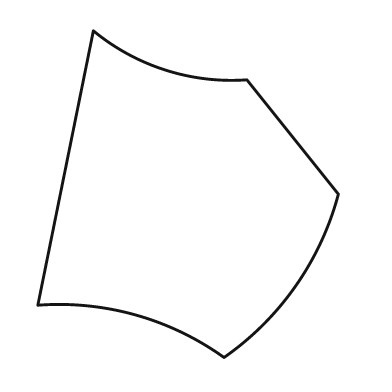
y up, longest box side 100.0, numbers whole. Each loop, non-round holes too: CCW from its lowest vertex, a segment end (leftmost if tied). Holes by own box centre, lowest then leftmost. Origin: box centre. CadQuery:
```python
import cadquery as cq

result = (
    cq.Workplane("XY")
    .moveTo(11.0, -50.0)
    .threePointArc((33.0, -28.0), (46.0, 0.0))
    .lineTo(18.0, 35.0)
    .threePointArc((-7.0, 38.0), (-29.0, 50.0))
    .lineTo(-46.0, -34.0)
    .threePointArc((-16.0, -37.0), (11.0, -50.0))
    .close()
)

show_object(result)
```